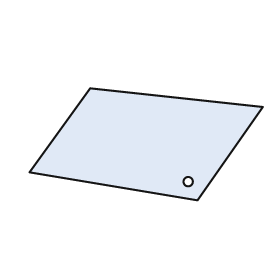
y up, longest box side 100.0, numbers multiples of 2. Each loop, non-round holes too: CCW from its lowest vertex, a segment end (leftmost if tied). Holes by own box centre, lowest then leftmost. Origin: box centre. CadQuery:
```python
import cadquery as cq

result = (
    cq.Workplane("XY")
    .moveTo(22.0, -24.0)
    .lineTo(50.0, 16.0)
    .lineTo(-24.0, 24.0)
    .lineTo(-50.0, -12.0)
    .close()
    .moveTo(18.0, -16.0)
    .circle(2.0)
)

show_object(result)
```